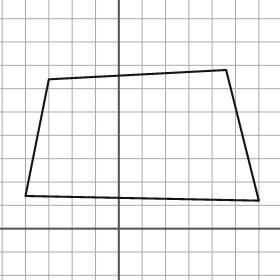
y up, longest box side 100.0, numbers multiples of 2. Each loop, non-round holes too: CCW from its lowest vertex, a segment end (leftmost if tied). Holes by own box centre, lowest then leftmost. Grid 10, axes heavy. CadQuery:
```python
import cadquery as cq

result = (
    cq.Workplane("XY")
    .moveTo(60.0, 12.0)
    .lineTo(46.0, 68.0)
    .lineTo(-30.0, 64.0)
    .lineTo(-40.0, 14.0)
    .close()
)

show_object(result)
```